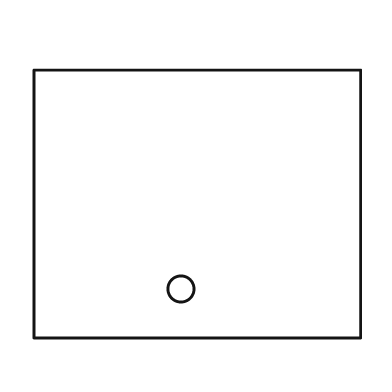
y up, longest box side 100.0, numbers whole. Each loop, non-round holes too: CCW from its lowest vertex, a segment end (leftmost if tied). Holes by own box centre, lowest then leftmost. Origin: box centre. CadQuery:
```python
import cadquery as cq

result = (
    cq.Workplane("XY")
    .moveTo(-50.0, -41.0)
    .lineTo(50.0, -41.0)
    .lineTo(50.0, 41.0)
    .lineTo(-50.0, 41.0)
    .close()
    .moveTo(-5.0, -26.0)
    .circle(4.0)
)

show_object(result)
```